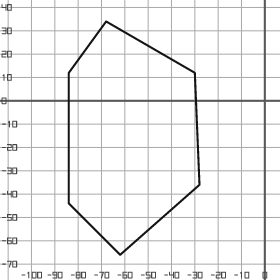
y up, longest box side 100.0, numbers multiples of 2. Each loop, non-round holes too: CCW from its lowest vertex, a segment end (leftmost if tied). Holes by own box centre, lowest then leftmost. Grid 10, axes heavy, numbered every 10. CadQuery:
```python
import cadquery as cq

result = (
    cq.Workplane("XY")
    .moveTo(-62.0, -66.0)
    .lineTo(-28.0, -36.0)
    .lineTo(-30.0, 12.0)
    .lineTo(-68.0, 34.0)
    .lineTo(-84.0, 12.0)
    .lineTo(-84.0, -44.0)
    .close()
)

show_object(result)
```